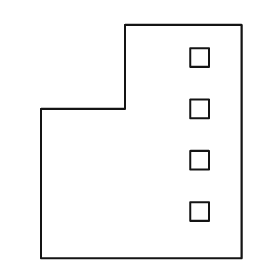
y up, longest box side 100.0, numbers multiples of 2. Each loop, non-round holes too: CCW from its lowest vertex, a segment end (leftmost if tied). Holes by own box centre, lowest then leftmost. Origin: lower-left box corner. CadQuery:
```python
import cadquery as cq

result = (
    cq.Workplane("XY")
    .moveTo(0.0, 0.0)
    .lineTo(86.0, 0.0)
    .lineTo(86.0, 100.0)
    .lineTo(36.0, 100.0)
    .lineTo(36.0, 64.0)
    .lineTo(0.0, 64.0)
    .close()
    .moveTo(64.0, 16.0)
    .lineTo(72.0, 16.0)
    .lineTo(72.0, 24.0)
    .lineTo(64.0, 24.0)
    .close()
    .moveTo(64.0, 38.0)
    .lineTo(72.0, 38.0)
    .lineTo(72.0, 46.0)
    .lineTo(64.0, 46.0)
    .close()
    .moveTo(64.0, 60.0)
    .lineTo(72.0, 60.0)
    .lineTo(72.0, 68.0)
    .lineTo(64.0, 68.0)
    .close()
    .moveTo(64.0, 82.0)
    .lineTo(72.0, 82.0)
    .lineTo(72.0, 90.0)
    .lineTo(64.0, 90.0)
    .close()
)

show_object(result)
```